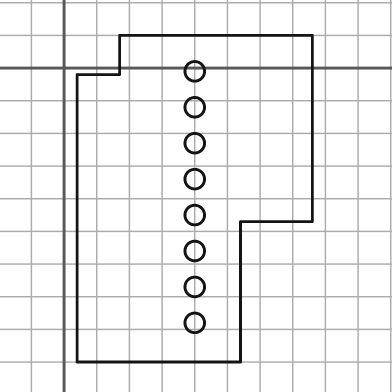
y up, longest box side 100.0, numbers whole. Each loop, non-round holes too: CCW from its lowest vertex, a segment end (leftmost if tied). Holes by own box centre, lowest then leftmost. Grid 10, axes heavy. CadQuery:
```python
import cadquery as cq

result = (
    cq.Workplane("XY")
    .moveTo(4.0, -90.0)
    .lineTo(54.0, -90.0)
    .lineTo(54.0, -47.0)
    .lineTo(76.0, -47.0)
    .lineTo(76.0, 10.0)
    .lineTo(17.0, 10.0)
    .lineTo(17.0, -2.0)
    .lineTo(4.0, -2.0)
    .close()
    .moveTo(40.0, -78.0)
    .circle(3.0)
    .moveTo(40.0, -67.0)
    .circle(3.0)
    .moveTo(40.0, -56.0)
    .circle(3.0)
    .moveTo(40.0, -45.0)
    .circle(3.0)
    .moveTo(40.0, -34.0)
    .circle(3.0)
    .moveTo(40.0, -23.0)
    .circle(3.0)
    .moveTo(40.0, -12.0)
    .circle(3.0)
    .moveTo(40.0, -1.0)
    .circle(3.0)
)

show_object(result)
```